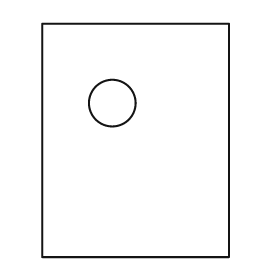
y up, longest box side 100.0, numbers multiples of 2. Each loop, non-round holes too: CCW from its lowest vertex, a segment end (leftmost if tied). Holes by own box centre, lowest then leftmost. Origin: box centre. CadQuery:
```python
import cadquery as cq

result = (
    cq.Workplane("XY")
    .moveTo(-40.0, -50.0)
    .lineTo(40.0, -50.0)
    .lineTo(40.0, 50.0)
    .lineTo(-40.0, 50.0)
    .close()
    .moveTo(-10.0, 16.0)
    .circle(10.0)
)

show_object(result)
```